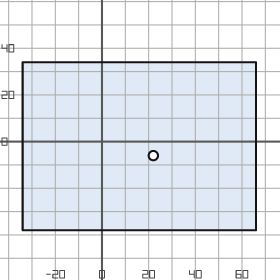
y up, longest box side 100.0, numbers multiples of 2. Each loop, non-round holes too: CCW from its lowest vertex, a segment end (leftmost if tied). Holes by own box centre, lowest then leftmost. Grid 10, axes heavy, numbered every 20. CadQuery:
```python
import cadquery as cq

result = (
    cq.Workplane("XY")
    .moveTo(-34.0, -38.0)
    .lineTo(66.0, -38.0)
    .lineTo(66.0, 34.0)
    .lineTo(-34.0, 34.0)
    .close()
    .moveTo(22.0, -6.0)
    .circle(2.0)
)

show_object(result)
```